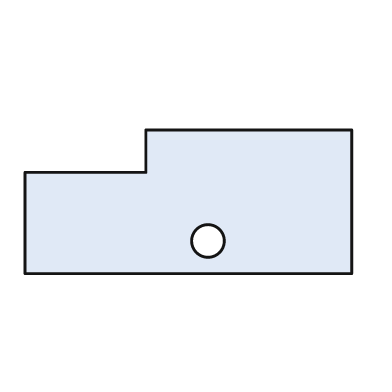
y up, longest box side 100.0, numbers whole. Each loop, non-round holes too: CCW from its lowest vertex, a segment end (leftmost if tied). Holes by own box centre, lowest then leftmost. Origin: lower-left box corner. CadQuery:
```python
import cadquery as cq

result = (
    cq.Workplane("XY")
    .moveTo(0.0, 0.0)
    .lineTo(100.0, 0.0)
    .lineTo(100.0, 44.0)
    .lineTo(37.0, 44.0)
    .lineTo(37.0, 31.0)
    .lineTo(0.0, 31.0)
    .close()
    .moveTo(56.0, 10.0)
    .circle(5.0)
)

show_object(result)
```